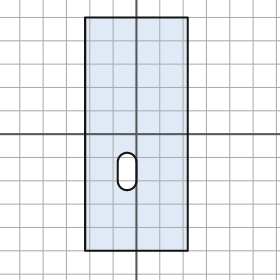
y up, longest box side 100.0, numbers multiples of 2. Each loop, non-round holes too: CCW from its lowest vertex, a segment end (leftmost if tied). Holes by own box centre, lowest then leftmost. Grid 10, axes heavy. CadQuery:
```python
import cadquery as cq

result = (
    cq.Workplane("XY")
    .moveTo(-22.0, -50.0)
    .lineTo(22.0, -50.0)
    .lineTo(22.0, 50.0)
    .lineTo(-22.0, 50.0)
    .close()
    .moveTo(-8.0, -20.0)
    .threePointArc((-4.0, -24.0), (0.0, -20.0))
    .lineTo(0.0, -12.0)
    .threePointArc((-4.0, -8.0), (-8.0, -12.0))
    .close()
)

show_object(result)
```